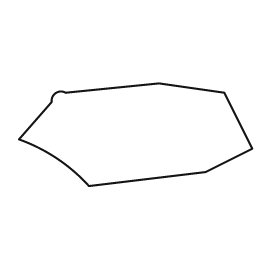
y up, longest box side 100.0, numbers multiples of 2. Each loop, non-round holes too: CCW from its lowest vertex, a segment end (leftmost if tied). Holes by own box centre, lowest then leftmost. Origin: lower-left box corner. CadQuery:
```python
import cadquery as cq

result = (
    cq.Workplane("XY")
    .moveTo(30.0, 0.0)
    .lineTo(80.0, 6.0)
    .lineTo(100.0, 16.0)
    .lineTo(88.0, 40.0)
    .lineTo(60.0, 44.0)
    .lineTo(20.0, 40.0)
    .threePointArc((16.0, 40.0), (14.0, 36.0))
    .lineTo(0.0, 20.0)
    .threePointArc((16.0, 12.0), (30.0, 0.0))
    .close()
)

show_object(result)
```